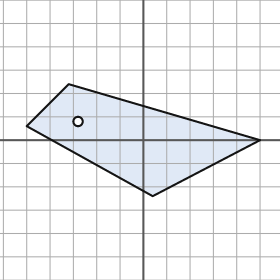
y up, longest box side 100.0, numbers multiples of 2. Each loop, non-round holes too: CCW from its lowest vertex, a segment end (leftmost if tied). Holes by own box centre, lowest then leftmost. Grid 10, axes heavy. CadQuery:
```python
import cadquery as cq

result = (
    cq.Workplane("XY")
    .moveTo(4.0, -24.0)
    .lineTo(50.0, 0.0)
    .lineTo(-32.0, 24.0)
    .lineTo(-50.0, 6.0)
    .close()
    .moveTo(-28.0, 8.0)
    .circle(2.0)
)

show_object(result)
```